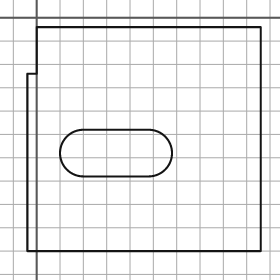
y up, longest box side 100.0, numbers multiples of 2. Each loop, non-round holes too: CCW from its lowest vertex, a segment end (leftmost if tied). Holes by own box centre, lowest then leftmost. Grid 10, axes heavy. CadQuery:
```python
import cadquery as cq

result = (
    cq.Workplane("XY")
    .moveTo(-4.0, -100.0)
    .lineTo(96.0, -100.0)
    .lineTo(96.0, -4.0)
    .lineTo(0.0, -4.0)
    .lineTo(0.0, -24.0)
    .lineTo(-4.0, -24.0)
    .close()
    .moveTo(20.0, -68.0)
    .lineTo(48.0, -68.0)
    .threePointArc((58.0, -58.0), (48.0, -48.0))
    .lineTo(20.0, -48.0)
    .threePointArc((10.0, -58.0), (20.0, -68.0))
    .close()
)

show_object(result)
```